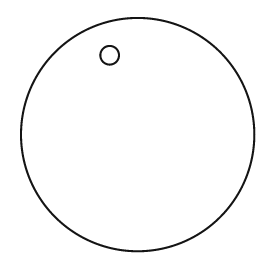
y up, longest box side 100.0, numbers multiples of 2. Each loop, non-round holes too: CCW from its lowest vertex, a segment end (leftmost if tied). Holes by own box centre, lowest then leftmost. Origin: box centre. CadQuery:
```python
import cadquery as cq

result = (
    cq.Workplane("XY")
    .moveTo(0.0, 0.0)
    .circle(50.0)
    .moveTo(-12.0, 34.0)
    .circle(4.0)
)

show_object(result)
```